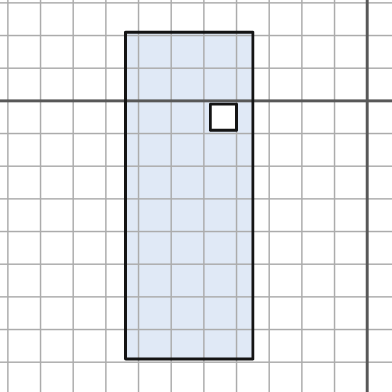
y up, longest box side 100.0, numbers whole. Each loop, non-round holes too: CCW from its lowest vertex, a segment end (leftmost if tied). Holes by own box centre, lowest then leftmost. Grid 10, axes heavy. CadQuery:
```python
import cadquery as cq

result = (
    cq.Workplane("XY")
    .moveTo(-74.0, -79.0)
    .lineTo(-35.0, -79.0)
    .lineTo(-35.0, 21.0)
    .lineTo(-74.0, 21.0)
    .close()
    .moveTo(-48.0, -9.0)
    .lineTo(-40.0, -9.0)
    .lineTo(-40.0, -1.0)
    .lineTo(-48.0, -1.0)
    .close()
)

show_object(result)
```